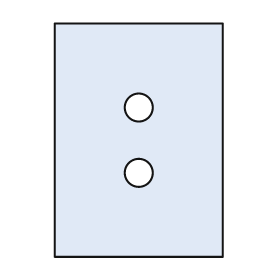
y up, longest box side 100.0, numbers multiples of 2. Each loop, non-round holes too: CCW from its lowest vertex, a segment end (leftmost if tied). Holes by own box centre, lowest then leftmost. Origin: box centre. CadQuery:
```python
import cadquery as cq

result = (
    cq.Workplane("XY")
    .moveTo(-36.0, -50.0)
    .lineTo(36.0, -50.0)
    .lineTo(36.0, 50.0)
    .lineTo(-36.0, 50.0)
    .close()
    .moveTo(0.0, -14.0)
    .circle(6.0)
    .moveTo(0.0, 14.0)
    .circle(6.0)
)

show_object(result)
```